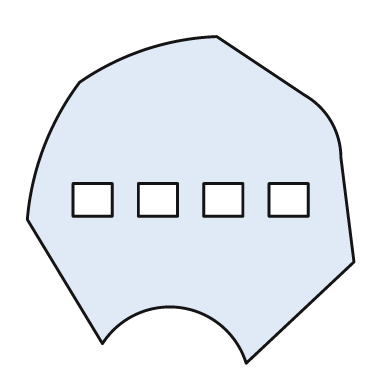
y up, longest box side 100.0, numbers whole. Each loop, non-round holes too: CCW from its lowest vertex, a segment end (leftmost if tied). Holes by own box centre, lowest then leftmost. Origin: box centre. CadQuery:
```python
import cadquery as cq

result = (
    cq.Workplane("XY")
    .moveTo(17.0, -50.0)
    .lineTo(50.0, -19.0)
    .lineTo(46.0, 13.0)
    .threePointArc((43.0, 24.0), (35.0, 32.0))
    .lineTo(8.0, 50.0)
    .threePointArc((-14.0, 46.0), (-34.0, 36.0))
    .threePointArc((-45.0, 16.0), (-50.0, -6.0))
    .lineTo(-27.0, -44.0)
    .threePointArc((-3.0, -33.0), (17.0, -50.0))
    .close()
    .moveTo(-36.0, -5.0)
    .lineTo(-24.0, -5.0)
    .lineTo(-24.0, 5.0)
    .lineTo(-36.0, 5.0)
    .close()
    .moveTo(-16.0, -5.0)
    .lineTo(-4.0, -5.0)
    .lineTo(-4.0, 5.0)
    .lineTo(-16.0, 5.0)
    .close()
    .moveTo(4.0, -5.0)
    .lineTo(16.0, -5.0)
    .lineTo(16.0, 5.0)
    .lineTo(4.0, 5.0)
    .close()
    .moveTo(24.0, -5.0)
    .lineTo(36.0, -5.0)
    .lineTo(36.0, 5.0)
    .lineTo(24.0, 5.0)
    .close()
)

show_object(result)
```